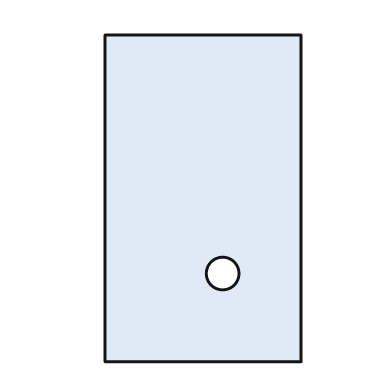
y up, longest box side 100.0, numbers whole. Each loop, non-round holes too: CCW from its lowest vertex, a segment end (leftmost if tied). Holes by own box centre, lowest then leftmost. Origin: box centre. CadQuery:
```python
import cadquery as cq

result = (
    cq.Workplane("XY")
    .moveTo(-30.0, -50.0)
    .lineTo(30.0, -50.0)
    .lineTo(30.0, 50.0)
    .lineTo(-30.0, 50.0)
    .close()
    .moveTo(6.0, -23.0)
    .circle(5.0)
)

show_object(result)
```